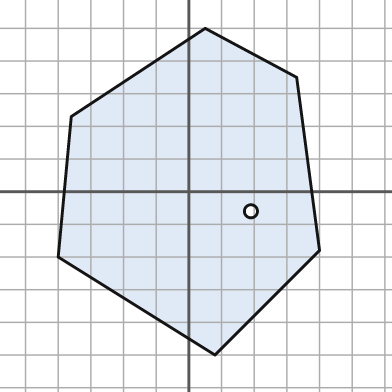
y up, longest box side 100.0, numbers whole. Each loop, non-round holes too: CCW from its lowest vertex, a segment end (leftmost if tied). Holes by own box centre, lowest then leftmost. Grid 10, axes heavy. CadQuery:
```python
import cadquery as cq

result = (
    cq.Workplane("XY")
    .moveTo(8.0, -50.0)
    .lineTo(40.0, -18.0)
    .lineTo(33.0, 35.0)
    .lineTo(5.0, 50.0)
    .lineTo(-36.0, 23.0)
    .lineTo(-40.0, -20.0)
    .close()
    .moveTo(19.0, -6.0)
    .circle(2.0)
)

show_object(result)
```